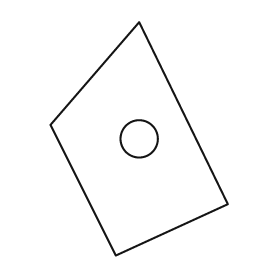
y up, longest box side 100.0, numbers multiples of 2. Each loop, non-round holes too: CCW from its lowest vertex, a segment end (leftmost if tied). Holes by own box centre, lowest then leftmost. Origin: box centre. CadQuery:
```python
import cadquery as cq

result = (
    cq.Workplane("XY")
    .moveTo(-10.0, -50.0)
    .lineTo(38.0, -28.0)
    .lineTo(0.0, 50.0)
    .lineTo(-38.0, 6.0)
    .close()
    .moveTo(0.0, 0.0)
    .circle(8.0)
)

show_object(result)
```